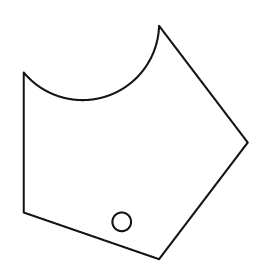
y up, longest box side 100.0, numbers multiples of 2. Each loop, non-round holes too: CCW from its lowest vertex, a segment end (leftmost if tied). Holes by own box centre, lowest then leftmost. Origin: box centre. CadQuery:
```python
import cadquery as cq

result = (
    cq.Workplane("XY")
    .moveTo(10.0, -50.0)
    .lineTo(48.0, 0.0)
    .lineTo(10.0, 50.0)
    .threePointArc((-12.0, 20.0), (-48.0, 30.0))
    .lineTo(-48.0, -30.0)
    .close()
    .moveTo(-6.0, -34.0)
    .circle(4.0)
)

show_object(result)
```